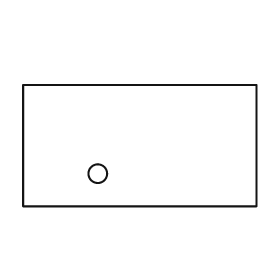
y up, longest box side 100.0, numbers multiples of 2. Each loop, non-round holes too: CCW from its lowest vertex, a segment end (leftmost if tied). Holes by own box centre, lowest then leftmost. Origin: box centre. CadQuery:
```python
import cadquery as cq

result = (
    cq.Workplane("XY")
    .moveTo(-50.0, -26.0)
    .lineTo(50.0, -26.0)
    .lineTo(50.0, 26.0)
    .lineTo(-50.0, 26.0)
    .close()
    .moveTo(-18.0, -12.0)
    .circle(4.0)
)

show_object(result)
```